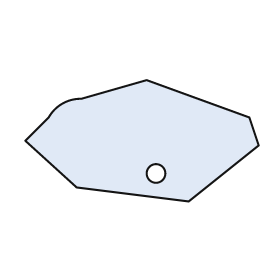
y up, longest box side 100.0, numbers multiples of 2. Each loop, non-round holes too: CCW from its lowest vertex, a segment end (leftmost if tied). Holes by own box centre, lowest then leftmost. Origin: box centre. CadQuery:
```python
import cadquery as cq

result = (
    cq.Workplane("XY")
    .moveTo(20.0, -26.0)
    .lineTo(50.0, -2.0)
    .lineTo(46.0, 10.0)
    .lineTo(2.0, 26.0)
    .lineTo(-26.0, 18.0)
    .threePointArc((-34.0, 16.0), (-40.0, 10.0))
    .lineTo(-50.0, 0.0)
    .lineTo(-28.0, -20.0)
    .close()
    .moveTo(6.0, -14.0)
    .circle(4.0)
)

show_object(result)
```